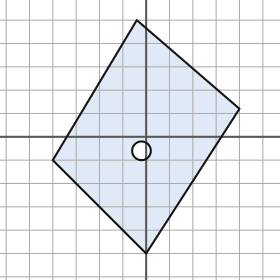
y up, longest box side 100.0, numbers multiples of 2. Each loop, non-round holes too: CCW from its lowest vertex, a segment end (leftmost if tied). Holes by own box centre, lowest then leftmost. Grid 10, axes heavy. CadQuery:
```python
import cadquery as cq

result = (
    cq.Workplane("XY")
    .moveTo(0.0, -50.0)
    .lineTo(40.0, 12.0)
    .lineTo(-4.0, 50.0)
    .lineTo(-40.0, -10.0)
    .close()
    .moveTo(-2.0, -6.0)
    .circle(4.0)
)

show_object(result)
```